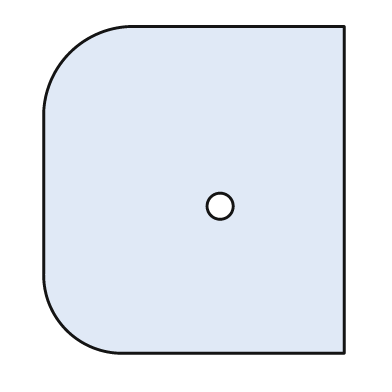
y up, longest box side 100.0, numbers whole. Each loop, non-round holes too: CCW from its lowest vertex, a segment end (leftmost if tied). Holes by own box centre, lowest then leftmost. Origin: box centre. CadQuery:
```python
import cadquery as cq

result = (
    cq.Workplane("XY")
    .moveTo(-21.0, -50.0)
    .lineTo(46.0, -50.0)
    .lineTo(46.0, 50.0)
    .lineTo(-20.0, 50.0)
    .threePointArc((-38.0, 42.0), (-46.0, 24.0))
    .lineTo(-46.0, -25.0)
    .threePointArc((-39.0, -43.0), (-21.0, -50.0))
    .close()
    .moveTo(8.0, -5.0)
    .circle(4.0)
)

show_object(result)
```